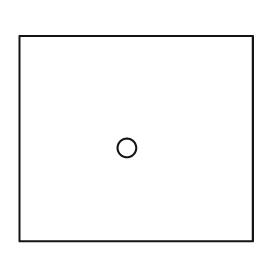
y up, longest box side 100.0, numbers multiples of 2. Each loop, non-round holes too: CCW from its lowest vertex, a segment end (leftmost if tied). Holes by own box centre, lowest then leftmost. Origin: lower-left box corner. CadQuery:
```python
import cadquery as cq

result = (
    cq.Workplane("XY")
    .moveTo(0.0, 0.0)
    .lineTo(100.0, 0.0)
    .lineTo(100.0, 88.0)
    .lineTo(0.0, 88.0)
    .close()
    .moveTo(46.0, 40.0)
    .circle(4.0)
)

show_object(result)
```